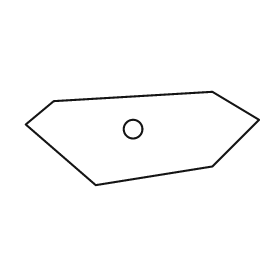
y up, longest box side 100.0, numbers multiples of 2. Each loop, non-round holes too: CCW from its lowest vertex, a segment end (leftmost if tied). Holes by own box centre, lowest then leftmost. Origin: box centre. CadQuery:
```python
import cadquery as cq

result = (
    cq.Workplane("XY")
    .moveTo(-20.0, -20.0)
    .lineTo(30.0, -12.0)
    .lineTo(50.0, 8.0)
    .lineTo(30.0, 20.0)
    .lineTo(-38.0, 16.0)
    .lineTo(-50.0, 6.0)
    .close()
    .moveTo(-4.0, 4.0)
    .circle(4.0)
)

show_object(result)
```